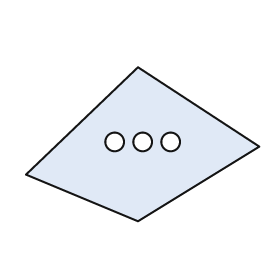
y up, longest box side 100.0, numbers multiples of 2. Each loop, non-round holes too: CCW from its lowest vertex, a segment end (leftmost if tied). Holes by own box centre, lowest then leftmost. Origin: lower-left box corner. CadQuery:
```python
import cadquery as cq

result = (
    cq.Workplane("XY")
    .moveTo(48.0, 0.0)
    .lineTo(100.0, 32.0)
    .lineTo(48.0, 66.0)
    .lineTo(0.0, 20.0)
    .close()
    .moveTo(38.0, 34.0)
    .circle(4.0)
    .moveTo(50.0, 34.0)
    .circle(4.0)
    .moveTo(62.0, 34.0)
    .circle(4.0)
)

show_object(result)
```